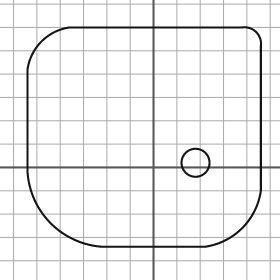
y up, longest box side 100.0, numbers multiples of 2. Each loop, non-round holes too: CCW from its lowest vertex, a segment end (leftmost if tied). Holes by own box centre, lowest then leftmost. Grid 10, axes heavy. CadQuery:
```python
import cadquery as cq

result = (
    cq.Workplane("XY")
    .moveTo(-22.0, -34.0)
    .lineTo(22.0, -34.0)
    .threePointArc((38.0, -26.0), (46.0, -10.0))
    .lineTo(46.0, 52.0)
    .threePointArc((44.0, 58.0), (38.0, 60.0))
    .lineTo(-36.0, 60.0)
    .threePointArc((-48.0, 54.0), (-54.0, 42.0))
    .lineTo(-54.0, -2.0)
    .threePointArc((-44.0, -24.0), (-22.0, -34.0))
    .close()
    .moveTo(18.0, 2.0)
    .circle(6.0)
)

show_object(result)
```